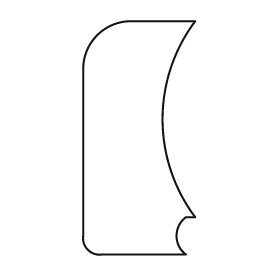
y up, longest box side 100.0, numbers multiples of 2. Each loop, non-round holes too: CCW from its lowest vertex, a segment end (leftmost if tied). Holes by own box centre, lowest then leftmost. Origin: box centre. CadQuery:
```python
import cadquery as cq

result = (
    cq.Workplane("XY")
    .moveTo(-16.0, -50.0)
    .lineTo(20.0, -50.0)
    .threePointArc((16.0, -42.0), (20.0, -34.0))
    .lineTo(24.0, -34.0)
    .threePointArc((10.0, 8.0), (24.0, 50.0))
    .lineTo(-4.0, 50.0)
    .threePointArc((-18.0, 44.0), (-24.0, 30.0))
    .lineTo(-24.0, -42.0)
    .threePointArc((-22.0, -48.0), (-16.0, -50.0))
    .close()
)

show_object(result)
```